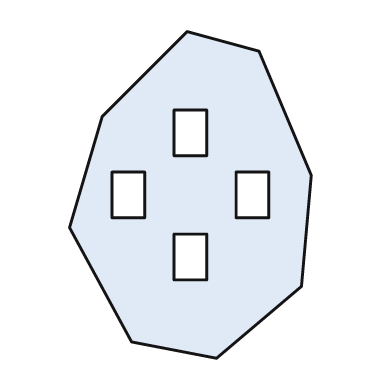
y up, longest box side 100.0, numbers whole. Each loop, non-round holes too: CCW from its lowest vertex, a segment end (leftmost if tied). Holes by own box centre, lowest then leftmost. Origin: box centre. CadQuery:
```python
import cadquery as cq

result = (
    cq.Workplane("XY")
    .moveTo(8.0, -50.0)
    .lineTo(34.0, -28.0)
    .lineTo(37.0, 6.0)
    .lineTo(21.0, 44.0)
    .lineTo(-1.0, 50.0)
    .lineTo(-27.0, 24.0)
    .lineTo(-37.0, -10.0)
    .lineTo(-18.0, -45.0)
    .close()
    .moveTo(-5.0, -26.0)
    .lineTo(5.0, -26.0)
    .lineTo(5.0, -12.0)
    .lineTo(-5.0, -12.0)
    .close()
    .moveTo(-24.0, -7.0)
    .lineTo(-14.0, -7.0)
    .lineTo(-14.0, 7.0)
    .lineTo(-24.0, 7.0)
    .close()
    .moveTo(14.0, -7.0)
    .lineTo(24.0, -7.0)
    .lineTo(24.0, 7.0)
    .lineTo(14.0, 7.0)
    .close()
    .moveTo(-5.0, 12.0)
    .lineTo(5.0, 12.0)
    .lineTo(5.0, 26.0)
    .lineTo(-5.0, 26.0)
    .close()
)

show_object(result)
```